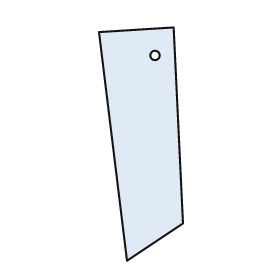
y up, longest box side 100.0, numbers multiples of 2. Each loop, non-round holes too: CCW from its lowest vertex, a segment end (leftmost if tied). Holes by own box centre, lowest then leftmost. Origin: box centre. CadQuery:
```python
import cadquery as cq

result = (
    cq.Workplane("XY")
    .moveTo(-6.0, -50.0)
    .lineTo(18.0, -34.0)
    .lineTo(14.0, 50.0)
    .lineTo(-18.0, 48.0)
    .close()
    .moveTo(6.0, 38.0)
    .circle(2.0)
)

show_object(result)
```